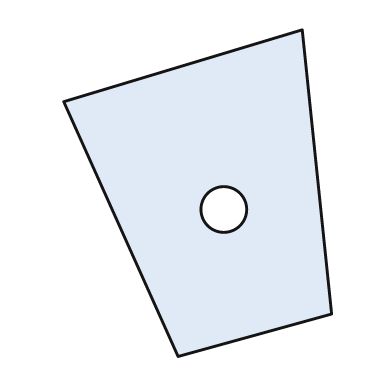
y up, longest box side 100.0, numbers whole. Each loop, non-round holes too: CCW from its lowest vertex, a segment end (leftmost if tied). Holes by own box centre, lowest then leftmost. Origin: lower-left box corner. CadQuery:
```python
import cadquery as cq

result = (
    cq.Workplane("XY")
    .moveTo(35.0, 0.0)
    .lineTo(82.0, 13.0)
    .lineTo(73.0, 100.0)
    .lineTo(0.0, 78.0)
    .close()
    .moveTo(49.0, 45.0)
    .circle(7.0)
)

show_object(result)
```